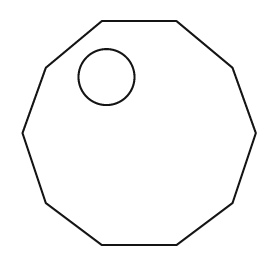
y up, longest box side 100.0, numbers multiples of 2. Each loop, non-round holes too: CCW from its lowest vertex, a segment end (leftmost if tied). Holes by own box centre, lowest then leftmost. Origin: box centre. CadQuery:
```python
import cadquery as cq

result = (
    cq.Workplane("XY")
    .moveTo(-16.0, -48.0)
    .lineTo(16.0, -48.0)
    .lineTo(40.0, -30.0)
    .lineTo(50.0, 0.0)
    .lineTo(40.0, 28.0)
    .lineTo(16.0, 48.0)
    .lineTo(-16.0, 48.0)
    .lineTo(-40.0, 28.0)
    .lineTo(-50.0, 0.0)
    .lineTo(-40.0, -30.0)
    .close()
    .moveTo(-14.0, 24.0)
    .circle(12.0)
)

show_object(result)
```